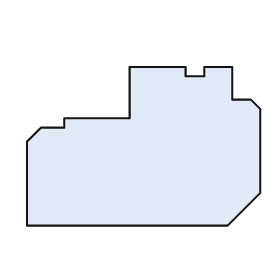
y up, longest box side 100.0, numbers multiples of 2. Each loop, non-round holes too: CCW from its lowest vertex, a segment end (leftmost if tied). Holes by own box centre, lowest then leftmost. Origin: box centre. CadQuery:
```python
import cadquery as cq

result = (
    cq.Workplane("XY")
    .moveTo(-50.0, -34.0)
    .lineTo(36.0, -34.0)
    .lineTo(50.0, -20.0)
    .lineTo(50.0, 16.0)
    .lineTo(46.0, 20.0)
    .lineTo(38.0, 20.0)
    .lineTo(38.0, 34.0)
    .lineTo(26.0, 34.0)
    .lineTo(26.0, 30.0)
    .lineTo(18.0, 30.0)
    .lineTo(18.0, 34.0)
    .lineTo(-6.0, 34.0)
    .lineTo(-6.0, 12.0)
    .lineTo(-34.0, 12.0)
    .lineTo(-34.0, 8.0)
    .lineTo(-44.0, 8.0)
    .lineTo(-50.0, 2.0)
    .close()
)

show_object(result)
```